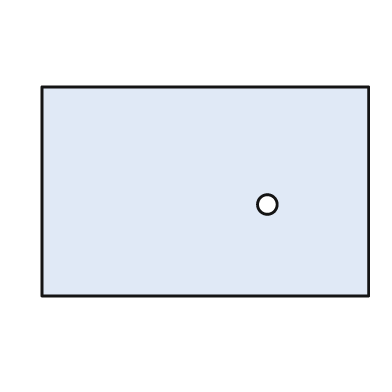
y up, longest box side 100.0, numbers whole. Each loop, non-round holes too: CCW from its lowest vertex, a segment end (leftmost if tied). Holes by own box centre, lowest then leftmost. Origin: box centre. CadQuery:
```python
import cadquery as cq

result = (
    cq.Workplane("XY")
    .moveTo(-50.0, -32.0)
    .lineTo(50.0, -32.0)
    .lineTo(50.0, 32.0)
    .lineTo(-50.0, 32.0)
    .close()
    .moveTo(19.0, -4.0)
    .circle(3.0)
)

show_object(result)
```